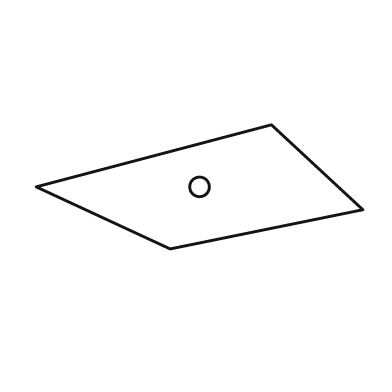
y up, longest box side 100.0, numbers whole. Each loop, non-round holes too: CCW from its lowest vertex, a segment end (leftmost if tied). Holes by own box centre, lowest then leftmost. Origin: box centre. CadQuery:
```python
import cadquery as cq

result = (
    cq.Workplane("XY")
    .moveTo(-9.0, -19.0)
    .lineTo(50.0, -7.0)
    .lineTo(22.0, 19.0)
    .lineTo(-50.0, 0.0)
    .close()
    .moveTo(0.0, 0.0)
    .circle(3.0)
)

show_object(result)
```